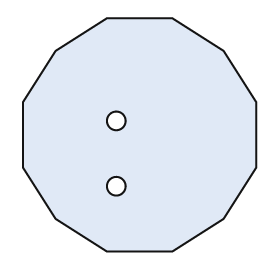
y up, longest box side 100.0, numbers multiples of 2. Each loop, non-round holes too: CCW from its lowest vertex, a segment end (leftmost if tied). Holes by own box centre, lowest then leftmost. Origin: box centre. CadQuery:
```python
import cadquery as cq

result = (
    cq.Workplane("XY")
    .moveTo(-14.0, -50.0)
    .lineTo(14.0, -50.0)
    .lineTo(36.0, -36.0)
    .lineTo(50.0, -14.0)
    .lineTo(50.0, 14.0)
    .lineTo(36.0, 36.0)
    .lineTo(14.0, 50.0)
    .lineTo(-14.0, 50.0)
    .lineTo(-36.0, 36.0)
    .lineTo(-50.0, 14.0)
    .lineTo(-50.0, -14.0)
    .lineTo(-36.0, -36.0)
    .close()
    .moveTo(-10.0, -22.0)
    .circle(4.0)
    .moveTo(-10.0, 6.0)
    .circle(4.0)
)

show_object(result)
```